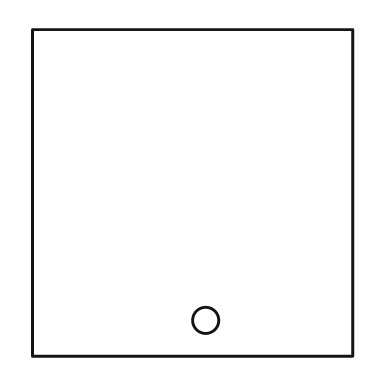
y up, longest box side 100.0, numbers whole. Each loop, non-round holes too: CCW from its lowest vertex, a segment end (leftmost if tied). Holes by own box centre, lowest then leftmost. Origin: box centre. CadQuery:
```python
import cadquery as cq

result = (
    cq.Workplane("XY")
    .moveTo(-49.0, -50.0)
    .lineTo(49.0, -50.0)
    .lineTo(49.0, 50.0)
    .lineTo(-49.0, 50.0)
    .close()
    .moveTo(4.0, -39.0)
    .circle(4.0)
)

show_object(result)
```